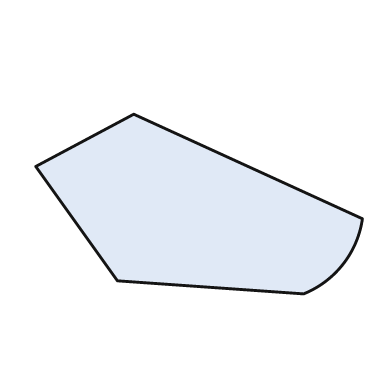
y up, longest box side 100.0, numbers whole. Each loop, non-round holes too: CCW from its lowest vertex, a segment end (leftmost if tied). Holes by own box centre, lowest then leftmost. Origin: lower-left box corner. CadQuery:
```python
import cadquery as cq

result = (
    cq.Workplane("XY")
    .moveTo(82.0, 0.0)
    .threePointArc((94.0, 9.0), (100.0, 23.0))
    .lineTo(30.0, 55.0)
    .lineTo(0.0, 39.0)
    .lineTo(25.0, 4.0)
    .close()
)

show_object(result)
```